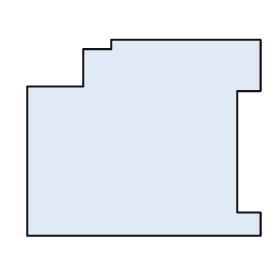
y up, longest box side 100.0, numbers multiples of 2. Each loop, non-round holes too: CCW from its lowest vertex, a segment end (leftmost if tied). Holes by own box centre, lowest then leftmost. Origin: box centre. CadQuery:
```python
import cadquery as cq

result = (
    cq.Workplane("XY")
    .moveTo(-50.0, -42.0)
    .lineTo(50.0, -42.0)
    .lineTo(50.0, -32.0)
    .lineTo(40.0, -32.0)
    .lineTo(40.0, 20.0)
    .lineTo(50.0, 20.0)
    .lineTo(50.0, 42.0)
    .lineTo(-14.0, 42.0)
    .lineTo(-14.0, 38.0)
    .lineTo(-26.0, 38.0)
    .lineTo(-26.0, 22.0)
    .lineTo(-50.0, 22.0)
    .close()
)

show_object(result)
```